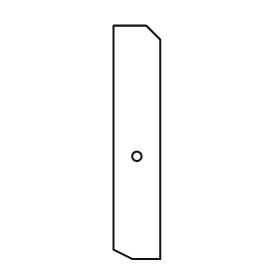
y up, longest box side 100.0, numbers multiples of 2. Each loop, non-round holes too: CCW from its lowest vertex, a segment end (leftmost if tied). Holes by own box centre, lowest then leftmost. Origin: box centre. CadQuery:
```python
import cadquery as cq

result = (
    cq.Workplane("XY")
    .moveTo(-2.0, -50.0)
    .lineTo(10.0, -50.0)
    .lineTo(10.0, 44.0)
    .lineTo(4.0, 50.0)
    .lineTo(-10.0, 50.0)
    .lineTo(-10.0, -46.0)
    .close()
    .moveTo(0.0, -6.0)
    .circle(2.0)
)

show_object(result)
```